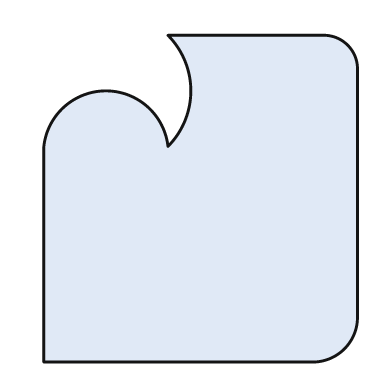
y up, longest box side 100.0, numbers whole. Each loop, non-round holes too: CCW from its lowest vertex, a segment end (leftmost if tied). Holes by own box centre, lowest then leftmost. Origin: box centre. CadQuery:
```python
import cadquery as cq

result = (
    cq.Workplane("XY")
    .moveTo(-48.0, -50.0)
    .lineTo(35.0, -50.0)
    .threePointArc((44.0, -46.0), (48.0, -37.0))
    .lineTo(48.0, 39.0)
    .threePointArc((45.0, 47.0), (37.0, 50.0))
    .lineTo(-10.0, 50.0)
    .threePointArc((-3.0, 33.0), (-10.0, 16.0))
    .threePointArc((-29.0, 33.0), (-48.0, 16.0))
    .close()
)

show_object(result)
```